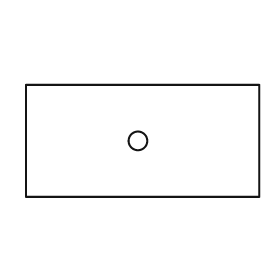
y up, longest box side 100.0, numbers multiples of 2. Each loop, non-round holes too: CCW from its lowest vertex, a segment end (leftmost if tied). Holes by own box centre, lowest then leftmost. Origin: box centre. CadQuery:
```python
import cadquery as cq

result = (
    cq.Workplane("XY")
    .moveTo(-50.0, -24.0)
    .lineTo(50.0, -24.0)
    .lineTo(50.0, 24.0)
    .lineTo(-50.0, 24.0)
    .close()
    .moveTo(-2.0, 0.0)
    .circle(4.0)
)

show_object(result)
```